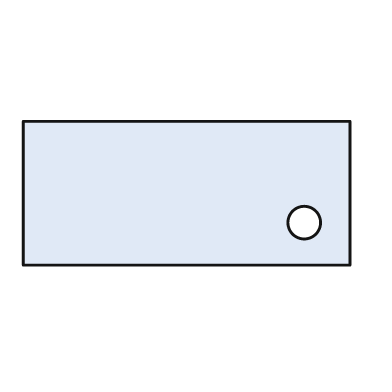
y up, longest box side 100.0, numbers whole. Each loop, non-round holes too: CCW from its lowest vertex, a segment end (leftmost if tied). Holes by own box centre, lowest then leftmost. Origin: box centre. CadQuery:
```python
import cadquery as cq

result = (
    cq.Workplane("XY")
    .moveTo(-50.0, -22.0)
    .lineTo(50.0, -22.0)
    .lineTo(50.0, 22.0)
    .lineTo(-50.0, 22.0)
    .close()
    .moveTo(36.0, -9.0)
    .circle(5.0)
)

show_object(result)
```